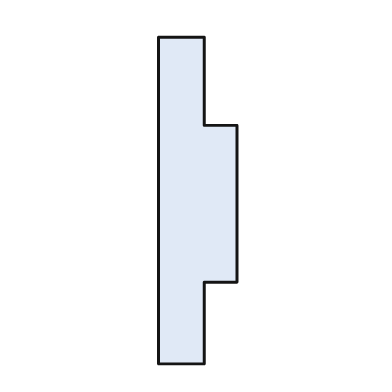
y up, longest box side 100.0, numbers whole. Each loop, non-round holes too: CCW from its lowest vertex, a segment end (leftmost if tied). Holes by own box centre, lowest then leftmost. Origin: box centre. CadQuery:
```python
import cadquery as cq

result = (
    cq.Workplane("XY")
    .moveTo(-12.0, -50.0)
    .lineTo(2.0, -50.0)
    .lineTo(2.0, -25.0)
    .lineTo(12.0, -25.0)
    .lineTo(12.0, 23.0)
    .lineTo(2.0, 23.0)
    .lineTo(2.0, 50.0)
    .lineTo(-12.0, 50.0)
    .close()
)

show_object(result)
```